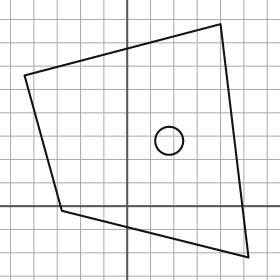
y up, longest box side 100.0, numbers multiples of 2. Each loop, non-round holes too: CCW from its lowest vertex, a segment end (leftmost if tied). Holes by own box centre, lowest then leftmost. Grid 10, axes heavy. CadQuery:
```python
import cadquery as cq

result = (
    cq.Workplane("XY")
    .moveTo(52.0, -22.0)
    .lineTo(40.0, 78.0)
    .lineTo(-44.0, 56.0)
    .lineTo(-28.0, -2.0)
    .close()
    .moveTo(18.0, 28.0)
    .circle(6.0)
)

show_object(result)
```